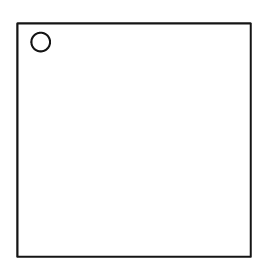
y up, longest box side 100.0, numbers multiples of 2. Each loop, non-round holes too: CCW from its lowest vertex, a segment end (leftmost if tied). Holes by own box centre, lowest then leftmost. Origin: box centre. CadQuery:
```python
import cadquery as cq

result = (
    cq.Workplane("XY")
    .moveTo(-50.0, -50.0)
    .lineTo(50.0, -50.0)
    .lineTo(50.0, 50.0)
    .lineTo(-50.0, 50.0)
    .close()
    .moveTo(-40.0, 42.0)
    .circle(4.0)
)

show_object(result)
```